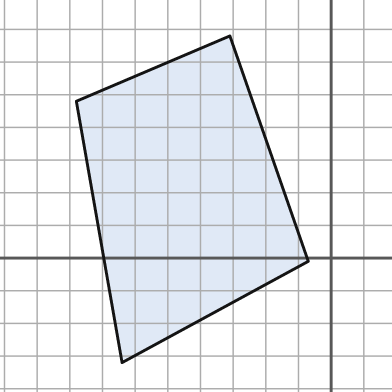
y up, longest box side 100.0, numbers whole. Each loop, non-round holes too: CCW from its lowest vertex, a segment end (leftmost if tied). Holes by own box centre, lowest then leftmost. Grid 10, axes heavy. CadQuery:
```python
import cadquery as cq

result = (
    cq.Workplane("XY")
    .moveTo(-64.0, -32.0)
    .lineTo(-7.0, -1.0)
    .lineTo(-31.0, 68.0)
    .lineTo(-78.0, 48.0)
    .close()
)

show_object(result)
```